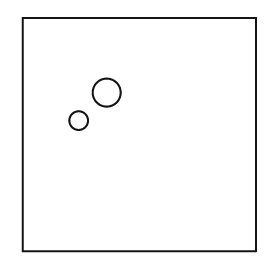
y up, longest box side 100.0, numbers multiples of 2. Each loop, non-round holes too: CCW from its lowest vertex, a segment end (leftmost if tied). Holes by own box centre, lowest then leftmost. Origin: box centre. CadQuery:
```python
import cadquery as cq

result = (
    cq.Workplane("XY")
    .moveTo(-50.0, -50.0)
    .lineTo(50.0, -50.0)
    .lineTo(50.0, 50.0)
    .lineTo(-50.0, 50.0)
    .close()
    .moveTo(-26.0, 6.0)
    .circle(4.0)
    .moveTo(-14.0, 18.0)
    .circle(6.0)
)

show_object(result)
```